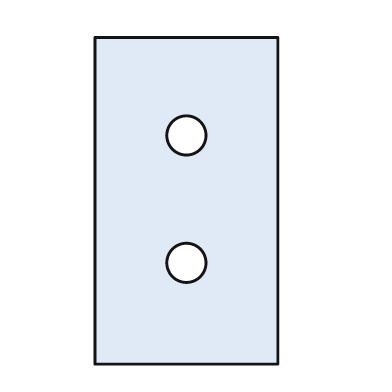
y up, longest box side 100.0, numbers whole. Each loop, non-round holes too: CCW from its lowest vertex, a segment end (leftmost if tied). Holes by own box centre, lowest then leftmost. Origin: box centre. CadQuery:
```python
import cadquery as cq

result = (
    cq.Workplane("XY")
    .moveTo(-28.0, -50.0)
    .lineTo(28.0, -50.0)
    .lineTo(28.0, 50.0)
    .lineTo(-28.0, 50.0)
    .close()
    .moveTo(0.0, -19.0)
    .circle(6.0)
    .moveTo(0.0, 20.0)
    .circle(6.0)
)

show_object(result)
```